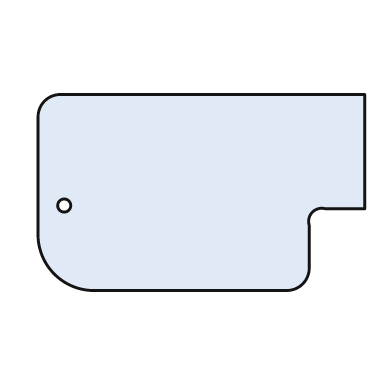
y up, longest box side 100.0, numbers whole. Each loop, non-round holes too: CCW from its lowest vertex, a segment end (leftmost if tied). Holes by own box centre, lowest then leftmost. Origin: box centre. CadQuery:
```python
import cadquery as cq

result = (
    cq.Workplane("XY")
    .moveTo(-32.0, -30.0)
    .lineTo(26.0, -30.0)
    .threePointArc((31.0, -28.0), (33.0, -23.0))
    .lineTo(33.0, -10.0)
    .threePointArc((34.0, -6.0), (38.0, -5.0))
    .lineTo(50.0, -5.0)
    .lineTo(50.0, 30.0)
    .lineTo(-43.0, 30.0)
    .threePointArc((-48.0, 28.0), (-50.0, 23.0))
    .lineTo(-50.0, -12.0)
    .threePointArc((-45.0, -25.0), (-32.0, -30.0))
    .close()
    .moveTo(-42.0, -4.0)
    .circle(2.0)
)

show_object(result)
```